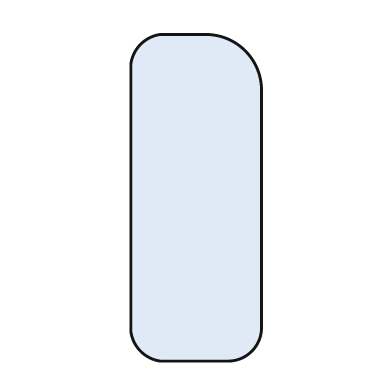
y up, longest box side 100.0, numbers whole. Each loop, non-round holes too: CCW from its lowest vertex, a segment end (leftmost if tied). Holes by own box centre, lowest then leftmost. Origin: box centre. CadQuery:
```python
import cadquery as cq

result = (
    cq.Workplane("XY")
    .moveTo(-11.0, -50.0)
    .lineTo(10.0, -50.0)
    .threePointArc((17.0, -47.0), (20.0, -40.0))
    .lineTo(20.0, 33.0)
    .threePointArc((15.0, 45.0), (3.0, 50.0))
    .lineTo(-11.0, 50.0)
    .threePointArc((-17.0, 47.0), (-20.0, 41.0))
    .lineTo(-20.0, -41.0)
    .threePointArc((-17.0, -47.0), (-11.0, -50.0))
    .close()
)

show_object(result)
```